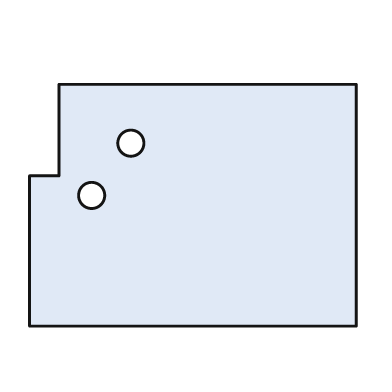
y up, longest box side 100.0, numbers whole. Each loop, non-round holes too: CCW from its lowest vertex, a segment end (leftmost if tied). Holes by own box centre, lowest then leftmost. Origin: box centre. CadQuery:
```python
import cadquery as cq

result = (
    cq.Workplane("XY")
    .moveTo(-50.0, -37.0)
    .lineTo(50.0, -37.0)
    .lineTo(50.0, 37.0)
    .lineTo(-41.0, 37.0)
    .lineTo(-41.0, 9.0)
    .lineTo(-50.0, 9.0)
    .close()
    .moveTo(-31.0, 3.0)
    .circle(4.0)
    .moveTo(-19.0, 19.0)
    .circle(4.0)
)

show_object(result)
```